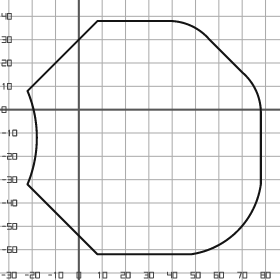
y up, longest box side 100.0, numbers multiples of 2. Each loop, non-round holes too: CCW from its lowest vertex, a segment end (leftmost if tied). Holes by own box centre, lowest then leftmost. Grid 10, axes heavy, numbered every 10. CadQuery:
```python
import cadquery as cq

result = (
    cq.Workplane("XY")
    .moveTo(8.0, -62.0)
    .lineTo(48.0, -62.0)
    .threePointArc((68.0, -52.0), (78.0, -32.0))
    .lineTo(78.0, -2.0)
    .threePointArc((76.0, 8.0), (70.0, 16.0))
    .lineTo(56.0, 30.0)
    .threePointArc((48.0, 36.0), (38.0, 38.0))
    .lineTo(8.0, 38.0)
    .lineTo(-22.0, 8.0)
    .threePointArc((-18.0, -12.0), (-22.0, -32.0))
    .close()
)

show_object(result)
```